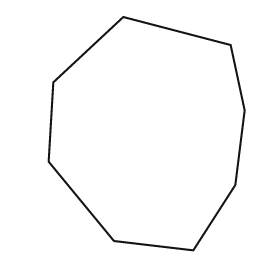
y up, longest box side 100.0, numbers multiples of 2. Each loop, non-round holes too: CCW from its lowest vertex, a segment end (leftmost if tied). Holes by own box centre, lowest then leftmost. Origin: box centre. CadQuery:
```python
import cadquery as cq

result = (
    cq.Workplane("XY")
    .moveTo(20.0, -50.0)
    .lineTo(38.0, -22.0)
    .lineTo(42.0, 10.0)
    .lineTo(36.0, 38.0)
    .lineTo(-10.0, 50.0)
    .lineTo(-40.0, 22.0)
    .lineTo(-42.0, -12.0)
    .lineTo(-14.0, -46.0)
    .close()
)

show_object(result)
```